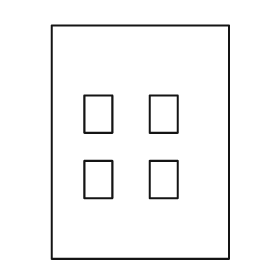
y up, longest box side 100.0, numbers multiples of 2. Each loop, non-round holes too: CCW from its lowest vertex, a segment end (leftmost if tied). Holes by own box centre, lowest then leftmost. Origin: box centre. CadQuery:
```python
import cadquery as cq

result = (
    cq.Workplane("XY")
    .moveTo(-38.0, -50.0)
    .lineTo(38.0, -50.0)
    .lineTo(38.0, 50.0)
    .lineTo(-38.0, 50.0)
    .close()
    .moveTo(-24.0, -24.0)
    .lineTo(-12.0, -24.0)
    .lineTo(-12.0, -8.0)
    .lineTo(-24.0, -8.0)
    .close()
    .moveTo(4.0, -24.0)
    .lineTo(16.0, -24.0)
    .lineTo(16.0, -8.0)
    .lineTo(4.0, -8.0)
    .close()
    .moveTo(-24.0, 4.0)
    .lineTo(-12.0, 4.0)
    .lineTo(-12.0, 20.0)
    .lineTo(-24.0, 20.0)
    .close()
    .moveTo(4.0, 4.0)
    .lineTo(16.0, 4.0)
    .lineTo(16.0, 20.0)
    .lineTo(4.0, 20.0)
    .close()
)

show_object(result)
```